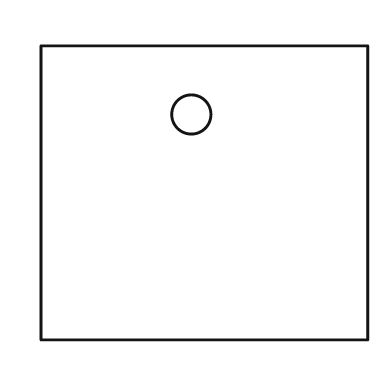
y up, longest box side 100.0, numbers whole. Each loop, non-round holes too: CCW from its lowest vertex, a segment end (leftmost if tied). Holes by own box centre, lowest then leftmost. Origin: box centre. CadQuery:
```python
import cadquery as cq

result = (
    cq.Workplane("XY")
    .moveTo(-50.0, -45.0)
    .lineTo(50.0, -45.0)
    .lineTo(50.0, 45.0)
    .lineTo(-50.0, 45.0)
    .close()
    .moveTo(-4.0, 24.0)
    .circle(6.0)
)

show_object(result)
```